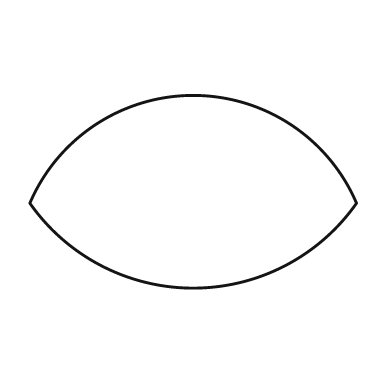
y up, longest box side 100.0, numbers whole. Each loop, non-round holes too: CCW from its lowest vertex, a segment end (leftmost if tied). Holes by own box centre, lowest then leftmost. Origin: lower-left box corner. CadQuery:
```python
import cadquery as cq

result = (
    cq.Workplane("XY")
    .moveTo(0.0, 26.0)
    .threePointArc((50.0, 0.0), (100.0, 26.0))
    .threePointArc((50.0, 59.0), (0.0, 26.0))
    .close()
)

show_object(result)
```